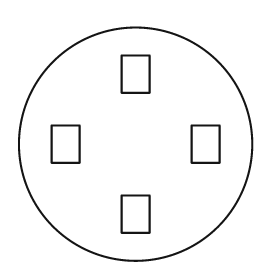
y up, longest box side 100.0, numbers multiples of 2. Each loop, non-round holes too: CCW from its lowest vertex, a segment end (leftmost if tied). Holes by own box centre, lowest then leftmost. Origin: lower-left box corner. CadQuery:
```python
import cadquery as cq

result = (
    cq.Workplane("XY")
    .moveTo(50.0, 50.0)
    .circle(50.0)
    .moveTo(44.0, 12.0)
    .lineTo(56.0, 12.0)
    .lineTo(56.0, 28.0)
    .lineTo(44.0, 28.0)
    .close()
    .moveTo(14.0, 42.0)
    .lineTo(26.0, 42.0)
    .lineTo(26.0, 58.0)
    .lineTo(14.0, 58.0)
    .close()
    .moveTo(74.0, 42.0)
    .lineTo(86.0, 42.0)
    .lineTo(86.0, 58.0)
    .lineTo(74.0, 58.0)
    .close()
    .moveTo(44.0, 72.0)
    .lineTo(56.0, 72.0)
    .lineTo(56.0, 88.0)
    .lineTo(44.0, 88.0)
    .close()
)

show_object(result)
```